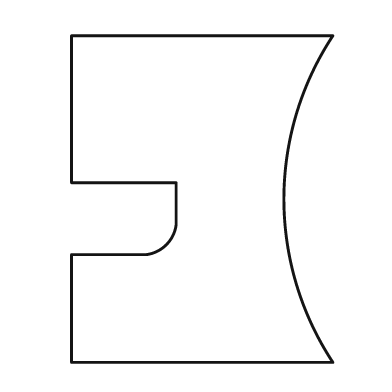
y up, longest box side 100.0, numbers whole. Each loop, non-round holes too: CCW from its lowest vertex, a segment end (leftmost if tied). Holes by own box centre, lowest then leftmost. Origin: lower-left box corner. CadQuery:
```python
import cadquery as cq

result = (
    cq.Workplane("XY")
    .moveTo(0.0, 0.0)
    .lineTo(80.0, 0.0)
    .threePointArc((65.0, 50.0), (80.0, 100.0))
    .lineTo(0.0, 100.0)
    .lineTo(0.0, 55.0)
    .lineTo(32.0, 55.0)
    .lineTo(32.0, 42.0)
    .threePointArc((29.0, 36.0), (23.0, 33.0))
    .lineTo(0.0, 33.0)
    .close()
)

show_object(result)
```